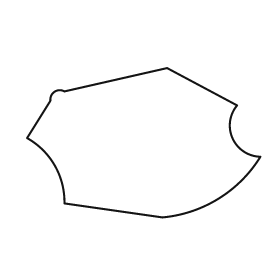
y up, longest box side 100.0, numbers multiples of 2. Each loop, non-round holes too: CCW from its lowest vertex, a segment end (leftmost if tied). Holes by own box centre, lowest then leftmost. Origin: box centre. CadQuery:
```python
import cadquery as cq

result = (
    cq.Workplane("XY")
    .moveTo(8.0, -32.0)
    .threePointArc((32.0, -24.0), (50.0, -6.0))
    .threePointArc((38.0, 2.0), (40.0, 16.0))
    .lineTo(10.0, 32.0)
    .lineTo(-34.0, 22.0)
    .threePointArc((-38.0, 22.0), (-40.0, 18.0))
    .lineTo(-50.0, 2.0)
    .threePointArc((-38.0, -10.0), (-34.0, -26.0))
    .close()
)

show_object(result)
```